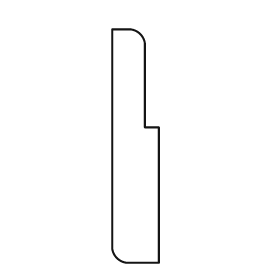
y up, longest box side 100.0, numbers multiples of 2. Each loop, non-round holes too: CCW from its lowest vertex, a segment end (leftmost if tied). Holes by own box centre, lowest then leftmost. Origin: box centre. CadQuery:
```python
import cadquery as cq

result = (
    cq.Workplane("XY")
    .moveTo(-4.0, -50.0)
    .lineTo(10.0, -50.0)
    .lineTo(10.0, 8.0)
    .lineTo(4.0, 8.0)
    .lineTo(4.0, 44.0)
    .threePointArc((2.0, 48.0), (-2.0, 50.0))
    .lineTo(-10.0, 50.0)
    .lineTo(-10.0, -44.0)
    .threePointArc((-8.0, -48.0), (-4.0, -50.0))
    .close()
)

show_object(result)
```